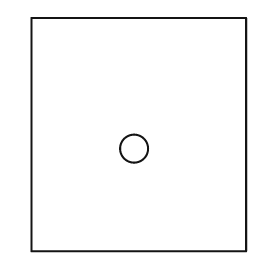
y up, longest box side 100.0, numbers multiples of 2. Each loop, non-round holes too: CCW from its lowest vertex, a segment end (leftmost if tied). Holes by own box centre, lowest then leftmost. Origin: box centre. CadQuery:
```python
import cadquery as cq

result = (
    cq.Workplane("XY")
    .moveTo(-46.0, -50.0)
    .lineTo(46.0, -50.0)
    .lineTo(46.0, 50.0)
    .lineTo(-46.0, 50.0)
    .close()
    .moveTo(-2.0, -6.0)
    .circle(6.0)
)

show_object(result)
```